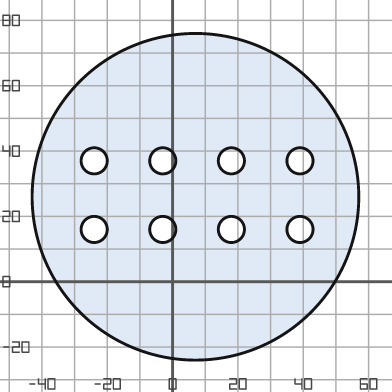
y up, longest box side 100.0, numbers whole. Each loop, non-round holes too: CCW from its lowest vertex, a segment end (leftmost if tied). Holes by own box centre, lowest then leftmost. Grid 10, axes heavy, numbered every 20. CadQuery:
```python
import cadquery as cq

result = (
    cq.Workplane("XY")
    .moveTo(7.0, 26.0)
    .circle(50.0)
    .moveTo(-24.0, 16.0)
    .circle(4.0)
    .moveTo(-3.0, 16.0)
    .circle(4.0)
    .moveTo(18.0, 16.0)
    .circle(4.0)
    .moveTo(39.0, 16.0)
    .circle(4.0)
    .moveTo(-24.0, 37.0)
    .circle(4.0)
    .moveTo(-3.0, 37.0)
    .circle(4.0)
    .moveTo(18.0, 37.0)
    .circle(4.0)
    .moveTo(39.0, 37.0)
    .circle(4.0)
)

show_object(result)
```